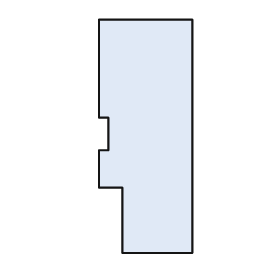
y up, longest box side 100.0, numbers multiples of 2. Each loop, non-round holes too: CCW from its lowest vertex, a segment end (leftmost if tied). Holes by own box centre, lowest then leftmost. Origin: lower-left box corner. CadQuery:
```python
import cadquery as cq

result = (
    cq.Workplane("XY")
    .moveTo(10.0, 0.0)
    .lineTo(40.0, 0.0)
    .lineTo(40.0, 100.0)
    .lineTo(0.0, 100.0)
    .lineTo(0.0, 58.0)
    .lineTo(4.0, 58.0)
    .lineTo(4.0, 44.0)
    .lineTo(0.0, 44.0)
    .lineTo(0.0, 28.0)
    .lineTo(10.0, 28.0)
    .close()
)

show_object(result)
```